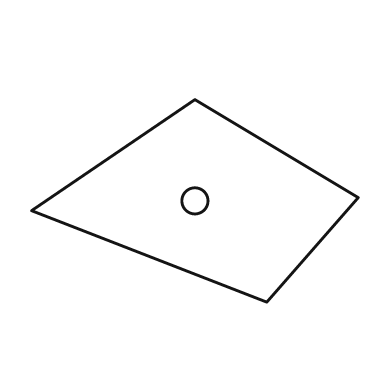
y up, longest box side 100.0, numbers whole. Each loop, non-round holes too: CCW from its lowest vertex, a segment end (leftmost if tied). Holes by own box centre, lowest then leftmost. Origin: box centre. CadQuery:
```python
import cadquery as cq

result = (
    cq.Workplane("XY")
    .moveTo(22.0, -31.0)
    .lineTo(50.0, 1.0)
    .lineTo(0.0, 31.0)
    .lineTo(-50.0, -3.0)
    .close()
    .moveTo(0.0, 0.0)
    .circle(4.0)
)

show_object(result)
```